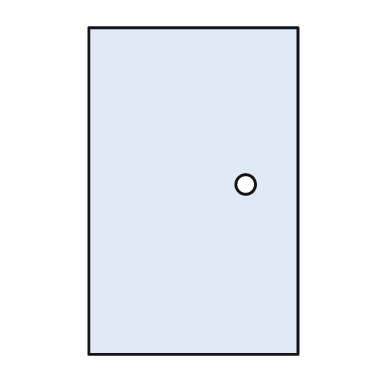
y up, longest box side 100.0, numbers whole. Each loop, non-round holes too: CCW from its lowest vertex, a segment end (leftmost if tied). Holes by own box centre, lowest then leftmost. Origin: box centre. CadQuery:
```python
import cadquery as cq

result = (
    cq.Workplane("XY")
    .moveTo(-32.0, -50.0)
    .lineTo(32.0, -50.0)
    .lineTo(32.0, 50.0)
    .lineTo(-32.0, 50.0)
    .close()
    .moveTo(16.0, 2.0)
    .circle(3.0)
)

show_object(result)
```